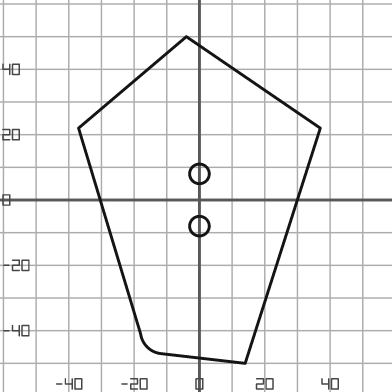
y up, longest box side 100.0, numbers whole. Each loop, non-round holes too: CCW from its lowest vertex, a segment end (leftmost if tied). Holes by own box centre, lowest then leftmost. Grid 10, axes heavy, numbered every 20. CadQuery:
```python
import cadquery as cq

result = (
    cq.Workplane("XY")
    .moveTo(14.0, -50.0)
    .lineTo(37.0, 22.0)
    .lineTo(-4.0, 50.0)
    .lineTo(-37.0, 22.0)
    .lineTo(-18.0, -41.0)
    .threePointArc((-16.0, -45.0), (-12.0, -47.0))
    .close()
    .moveTo(0.0, -8.0)
    .circle(3.0)
    .moveTo(0.0, 8.0)
    .circle(3.0)
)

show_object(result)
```